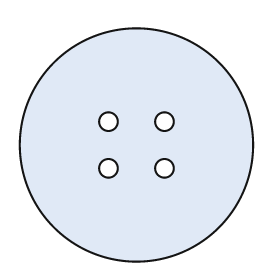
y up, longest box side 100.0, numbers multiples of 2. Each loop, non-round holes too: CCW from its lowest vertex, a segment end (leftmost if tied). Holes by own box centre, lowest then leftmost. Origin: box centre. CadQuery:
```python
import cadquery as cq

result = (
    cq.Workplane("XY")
    .moveTo(0.0, 0.0)
    .circle(50.0)
    .moveTo(-12.0, -10.0)
    .circle(4.0)
    .moveTo(12.0, -10.0)
    .circle(4.0)
    .moveTo(-12.0, 10.0)
    .circle(4.0)
    .moveTo(12.0, 10.0)
    .circle(4.0)
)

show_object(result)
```